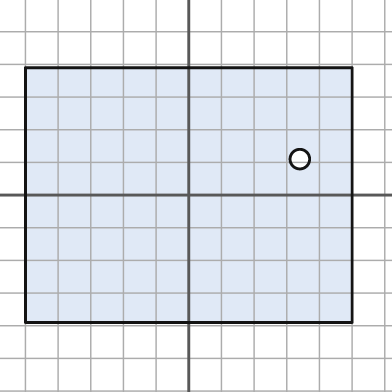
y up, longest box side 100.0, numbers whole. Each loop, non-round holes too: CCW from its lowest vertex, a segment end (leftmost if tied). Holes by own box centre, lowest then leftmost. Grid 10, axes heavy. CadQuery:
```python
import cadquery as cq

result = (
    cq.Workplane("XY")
    .moveTo(-50.0, -39.0)
    .lineTo(50.0, -39.0)
    .lineTo(50.0, 39.0)
    .lineTo(-50.0, 39.0)
    .close()
    .moveTo(34.0, 11.0)
    .circle(3.0)
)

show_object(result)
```